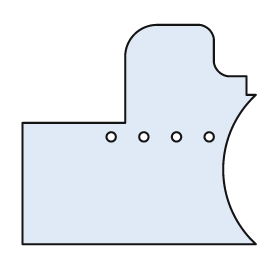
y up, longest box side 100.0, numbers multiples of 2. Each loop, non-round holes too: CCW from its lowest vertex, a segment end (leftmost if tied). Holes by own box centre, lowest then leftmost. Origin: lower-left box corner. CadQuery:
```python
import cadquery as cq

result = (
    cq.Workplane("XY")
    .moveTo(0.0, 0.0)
    .lineTo(100.0, 0.0)
    .threePointArc((86.0, 32.0), (100.0, 64.0))
    .lineTo(96.0, 64.0)
    .lineTo(96.0, 72.0)
    .lineTo(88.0, 72.0)
    .threePointArc((84.0, 74.0), (82.0, 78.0))
    .lineTo(82.0, 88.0)
    .threePointArc((80.0, 92.0), (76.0, 94.0))
    .lineTo(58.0, 94.0)
    .threePointArc((48.0, 90.0), (44.0, 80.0))
    .lineTo(44.0, 52.0)
    .lineTo(0.0, 52.0)
    .close()
    .moveTo(38.0, 46.0)
    .circle(2.0)
    .moveTo(52.0, 46.0)
    .circle(2.0)
    .moveTo(66.0, 46.0)
    .circle(2.0)
    .moveTo(80.0, 46.0)
    .circle(2.0)
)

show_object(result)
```